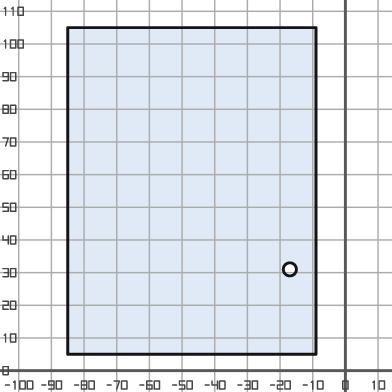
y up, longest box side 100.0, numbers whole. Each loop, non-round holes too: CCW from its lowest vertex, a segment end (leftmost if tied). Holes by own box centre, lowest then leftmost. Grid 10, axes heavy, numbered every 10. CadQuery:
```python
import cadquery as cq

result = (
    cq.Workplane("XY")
    .moveTo(-85.0, 5.0)
    .lineTo(-9.0, 5.0)
    .lineTo(-9.0, 105.0)
    .lineTo(-85.0, 105.0)
    .close()
    .moveTo(-17.0, 31.0)
    .circle(2.0)
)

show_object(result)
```